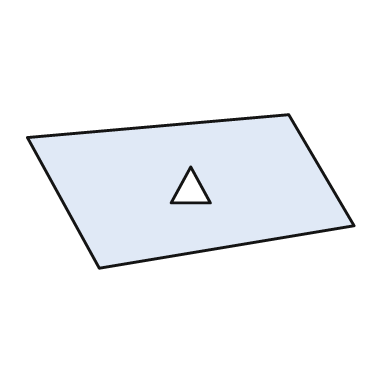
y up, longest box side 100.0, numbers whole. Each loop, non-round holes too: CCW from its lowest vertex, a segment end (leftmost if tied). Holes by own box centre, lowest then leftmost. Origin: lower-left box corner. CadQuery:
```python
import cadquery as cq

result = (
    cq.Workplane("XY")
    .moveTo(22.0, 0.0)
    .lineTo(100.0, 13.0)
    .lineTo(80.0, 47.0)
    .lineTo(0.0, 40.0)
    .close()
    .moveTo(44.0, 20.0)
    .lineTo(56.0, 20.0)
    .lineTo(50.0, 31.0)
    .close()
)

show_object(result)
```